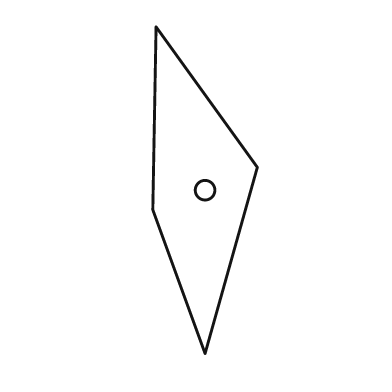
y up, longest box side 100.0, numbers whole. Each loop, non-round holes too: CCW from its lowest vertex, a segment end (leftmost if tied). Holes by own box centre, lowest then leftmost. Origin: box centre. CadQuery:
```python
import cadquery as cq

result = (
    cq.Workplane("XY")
    .moveTo(0.0, -50.0)
    .lineTo(16.0, 7.0)
    .lineTo(-15.0, 50.0)
    .lineTo(-16.0, -6.0)
    .close()
    .moveTo(0.0, 0.0)
    .circle(3.0)
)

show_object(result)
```